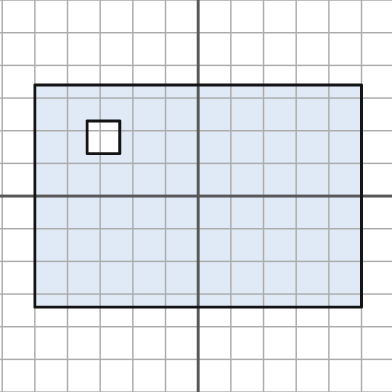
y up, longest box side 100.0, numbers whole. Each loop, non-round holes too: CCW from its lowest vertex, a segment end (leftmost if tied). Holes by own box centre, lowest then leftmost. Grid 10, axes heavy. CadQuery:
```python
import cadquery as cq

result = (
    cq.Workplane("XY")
    .moveTo(-50.0, -34.0)
    .lineTo(50.0, -34.0)
    .lineTo(50.0, 34.0)
    .lineTo(-50.0, 34.0)
    .close()
    .moveTo(-34.0, 13.0)
    .lineTo(-24.0, 13.0)
    .lineTo(-24.0, 23.0)
    .lineTo(-34.0, 23.0)
    .close()
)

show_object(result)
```